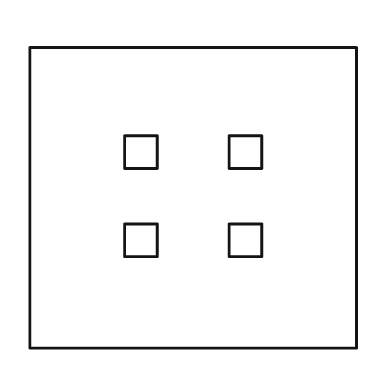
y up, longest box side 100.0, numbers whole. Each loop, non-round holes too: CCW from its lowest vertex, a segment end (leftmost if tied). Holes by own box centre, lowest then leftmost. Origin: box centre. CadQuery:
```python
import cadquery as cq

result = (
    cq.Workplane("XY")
    .moveTo(-50.0, -46.0)
    .lineTo(50.0, -46.0)
    .lineTo(50.0, 46.0)
    .lineTo(-50.0, 46.0)
    .close()
    .moveTo(-21.0, -18.0)
    .lineTo(-11.0, -18.0)
    .lineTo(-11.0, -8.0)
    .lineTo(-21.0, -8.0)
    .close()
    .moveTo(11.0, -18.0)
    .lineTo(21.0, -18.0)
    .lineTo(21.0, -8.0)
    .lineTo(11.0, -8.0)
    .close()
    .moveTo(-21.0, 9.0)
    .lineTo(-11.0, 9.0)
    .lineTo(-11.0, 19.0)
    .lineTo(-21.0, 19.0)
    .close()
    .moveTo(11.0, 9.0)
    .lineTo(21.0, 9.0)
    .lineTo(21.0, 19.0)
    .lineTo(11.0, 19.0)
    .close()
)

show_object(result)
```